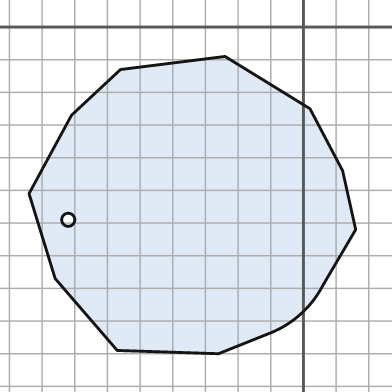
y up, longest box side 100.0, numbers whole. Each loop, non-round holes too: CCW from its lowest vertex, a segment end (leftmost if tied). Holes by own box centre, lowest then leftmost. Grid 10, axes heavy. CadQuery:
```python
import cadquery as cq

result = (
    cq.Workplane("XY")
    .moveTo(-26.0, -100.0)
    .lineTo(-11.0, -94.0)
    .threePointArc((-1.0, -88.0), (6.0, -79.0))
    .lineTo(16.0, -62.0)
    .lineTo(12.0, -44.0)
    .lineTo(2.0, -25.0)
    .lineTo(-24.0, -9.0)
    .lineTo(-56.0, -13.0)
    .lineTo(-71.0, -27.0)
    .lineTo(-84.0, -51.0)
    .lineTo(-76.0, -77.0)
    .lineTo(-57.0, -99.0)
    .close()
    .moveTo(-72.0, -59.0)
    .circle(2.0)
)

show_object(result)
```